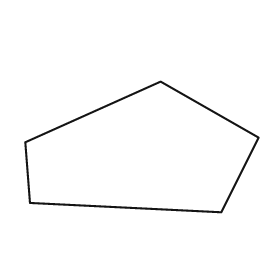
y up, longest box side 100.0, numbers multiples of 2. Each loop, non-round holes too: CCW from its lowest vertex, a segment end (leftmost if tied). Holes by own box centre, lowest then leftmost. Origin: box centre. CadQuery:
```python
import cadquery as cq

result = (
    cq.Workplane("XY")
    .moveTo(34.0, -28.0)
    .lineTo(50.0, 4.0)
    .lineTo(8.0, 28.0)
    .lineTo(-50.0, 2.0)
    .lineTo(-48.0, -24.0)
    .close()
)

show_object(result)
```